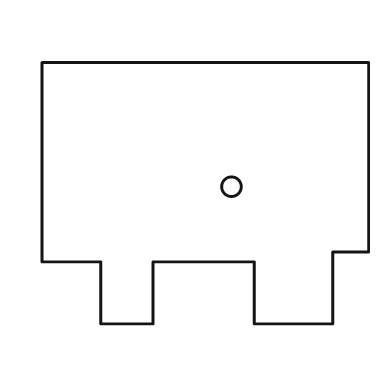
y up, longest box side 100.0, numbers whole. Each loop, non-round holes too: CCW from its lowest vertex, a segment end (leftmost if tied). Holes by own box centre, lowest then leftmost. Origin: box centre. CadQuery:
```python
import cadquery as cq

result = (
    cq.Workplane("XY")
    .moveTo(-32.0, -40.0)
    .lineTo(-16.0, -40.0)
    .lineTo(-16.0, -21.0)
    .lineTo(15.0, -21.0)
    .lineTo(15.0, -40.0)
    .lineTo(39.0, -40.0)
    .lineTo(39.0, -18.0)
    .lineTo(50.0, -18.0)
    .lineTo(50.0, 40.0)
    .lineTo(-50.0, 40.0)
    .lineTo(-50.0, -21.0)
    .lineTo(-32.0, -21.0)
    .close()
    .moveTo(8.0, 2.0)
    .circle(3.0)
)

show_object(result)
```